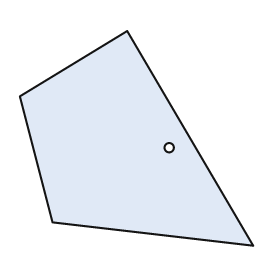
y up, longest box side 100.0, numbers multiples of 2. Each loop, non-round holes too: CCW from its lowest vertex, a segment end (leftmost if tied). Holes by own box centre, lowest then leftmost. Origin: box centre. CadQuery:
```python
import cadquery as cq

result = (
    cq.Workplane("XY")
    .moveTo(50.0, -46.0)
    .lineTo(-4.0, 46.0)
    .lineTo(-50.0, 18.0)
    .lineTo(-36.0, -36.0)
    .close()
    .moveTo(14.0, -4.0)
    .circle(2.0)
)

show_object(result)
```